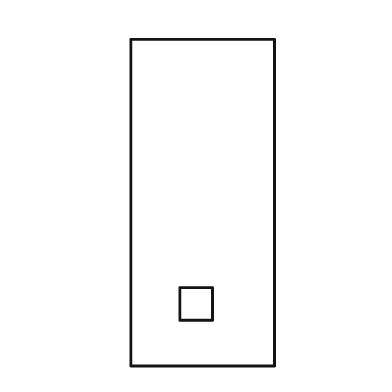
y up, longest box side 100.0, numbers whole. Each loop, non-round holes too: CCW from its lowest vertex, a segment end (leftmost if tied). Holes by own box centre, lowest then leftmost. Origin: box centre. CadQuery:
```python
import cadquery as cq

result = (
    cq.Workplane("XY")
    .moveTo(-22.0, -50.0)
    .lineTo(22.0, -50.0)
    .lineTo(22.0, 50.0)
    .lineTo(-22.0, 50.0)
    .close()
    .moveTo(-7.0, -36.0)
    .lineTo(3.0, -36.0)
    .lineTo(3.0, -26.0)
    .lineTo(-7.0, -26.0)
    .close()
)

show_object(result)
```